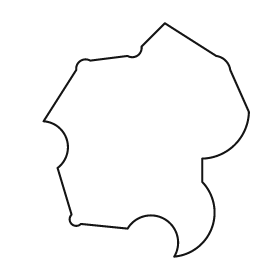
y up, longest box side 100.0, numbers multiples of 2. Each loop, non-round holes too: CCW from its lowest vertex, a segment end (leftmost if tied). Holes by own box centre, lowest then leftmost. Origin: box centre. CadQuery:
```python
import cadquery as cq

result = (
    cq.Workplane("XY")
    .moveTo(12.0, -50.0)
    .threePointArc((28.0, -38.0), (24.0, -18.0))
    .lineTo(24.0, -8.0)
    .threePointArc((38.0, -2.0), (44.0, 12.0))
    .lineTo(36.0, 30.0)
    .threePointArc((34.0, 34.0), (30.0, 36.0))
    .lineTo(8.0, 50.0)
    .lineTo(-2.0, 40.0)
    .threePointArc((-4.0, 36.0), (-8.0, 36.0))
    .lineTo(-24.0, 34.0)
    .threePointArc((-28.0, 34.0), (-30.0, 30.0))
    .lineTo(-44.0, 8.0)
    .threePointArc((-34.0, 0.0), (-38.0, -12.0))
    .lineTo(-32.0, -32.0)
    .threePointArc((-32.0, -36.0), (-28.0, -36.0))
    .lineTo(-8.0, -38.0)
    .threePointArc((8.0, -34.0), (12.0, -50.0))
    .close()
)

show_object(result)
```